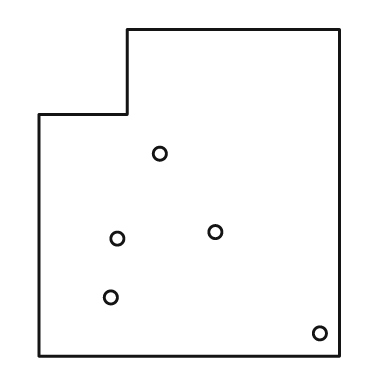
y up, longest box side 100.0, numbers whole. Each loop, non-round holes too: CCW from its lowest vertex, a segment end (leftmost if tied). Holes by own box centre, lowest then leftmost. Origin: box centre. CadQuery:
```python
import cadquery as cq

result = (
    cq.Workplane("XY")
    .moveTo(-46.0, -50.0)
    .lineTo(46.0, -50.0)
    .lineTo(46.0, 50.0)
    .lineTo(-19.0, 50.0)
    .lineTo(-19.0, 24.0)
    .lineTo(-46.0, 24.0)
    .close()
    .moveTo(40.0, -43.0)
    .circle(2.0)
    .moveTo(-24.0, -32.0)
    .circle(2.0)
    .moveTo(-22.0, -14.0)
    .circle(2.0)
    .moveTo(8.0, -12.0)
    .circle(2.0)
    .moveTo(-9.0, 12.0)
    .circle(2.0)
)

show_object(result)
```